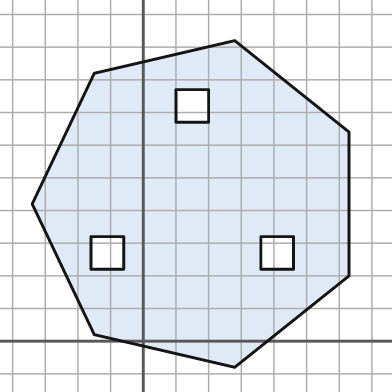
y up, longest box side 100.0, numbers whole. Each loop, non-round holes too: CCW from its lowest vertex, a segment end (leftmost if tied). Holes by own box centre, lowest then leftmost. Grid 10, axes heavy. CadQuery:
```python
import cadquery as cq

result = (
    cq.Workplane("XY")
    .moveTo(28.0, -8.0)
    .lineTo(63.0, 20.0)
    .lineTo(63.0, 64.0)
    .lineTo(28.0, 92.0)
    .lineTo(-15.0, 82.0)
    .lineTo(-34.0, 42.0)
    .lineTo(-15.0, 2.0)
    .close()
    .moveTo(-16.0, 22.0)
    .lineTo(-6.0, 22.0)
    .lineTo(-6.0, 32.0)
    .lineTo(-16.0, 32.0)
    .close()
    .moveTo(36.0, 22.0)
    .lineTo(46.0, 22.0)
    .lineTo(46.0, 32.0)
    .lineTo(36.0, 32.0)
    .close()
    .moveTo(10.0, 67.0)
    .lineTo(20.0, 67.0)
    .lineTo(20.0, 77.0)
    .lineTo(10.0, 77.0)
    .close()
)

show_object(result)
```